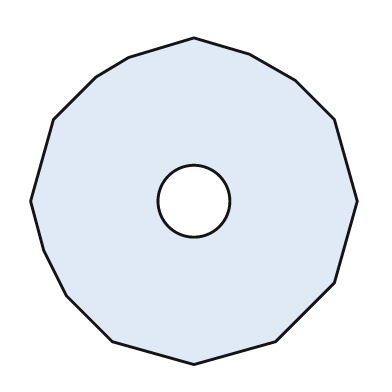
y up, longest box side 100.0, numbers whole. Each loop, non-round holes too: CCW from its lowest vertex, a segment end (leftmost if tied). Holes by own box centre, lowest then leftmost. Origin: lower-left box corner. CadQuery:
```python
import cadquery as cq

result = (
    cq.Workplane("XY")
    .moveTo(50.0, 0.0)
    .lineTo(75.0, 7.0)
    .lineTo(93.0, 25.0)
    .lineTo(100.0, 50.0)
    .lineTo(93.0, 75.0)
    .lineTo(81.0, 87.0)
    .lineTo(67.0, 95.0)
    .lineTo(50.0, 100.0)
    .lineTo(30.0, 94.0)
    .lineTo(20.0, 88.0)
    .lineTo(7.0, 75.0)
    .lineTo(0.0, 50.0)
    .lineTo(4.0, 35.0)
    .lineTo(11.0, 21.0)
    .lineTo(25.0, 7.0)
    .close()
    .moveTo(50.0, 50.0)
    .circle(11.0)
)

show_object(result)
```